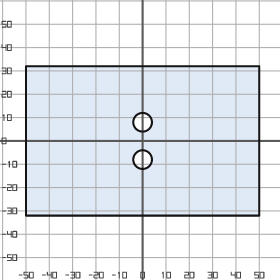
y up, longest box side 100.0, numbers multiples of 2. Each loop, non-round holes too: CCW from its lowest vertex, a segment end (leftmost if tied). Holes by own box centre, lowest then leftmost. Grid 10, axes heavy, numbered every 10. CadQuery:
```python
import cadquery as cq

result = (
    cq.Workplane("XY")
    .moveTo(-50.0, -32.0)
    .lineTo(50.0, -32.0)
    .lineTo(50.0, 32.0)
    .lineTo(-50.0, 32.0)
    .close()
    .moveTo(0.0, -8.0)
    .circle(4.0)
    .moveTo(0.0, 8.0)
    .circle(4.0)
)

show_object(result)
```